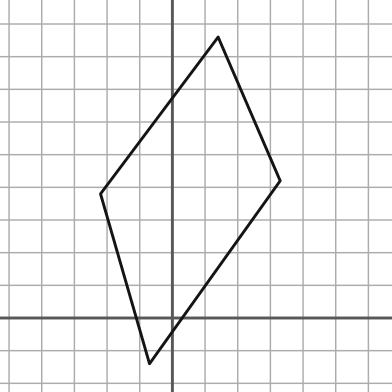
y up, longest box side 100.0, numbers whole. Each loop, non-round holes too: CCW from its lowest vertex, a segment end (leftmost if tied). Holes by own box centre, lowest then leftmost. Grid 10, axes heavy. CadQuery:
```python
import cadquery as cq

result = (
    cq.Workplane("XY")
    .moveTo(-7.0, -14.0)
    .lineTo(33.0, 42.0)
    .lineTo(14.0, 86.0)
    .lineTo(-22.0, 38.0)
    .close()
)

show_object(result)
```